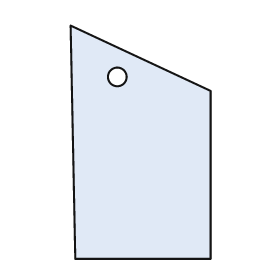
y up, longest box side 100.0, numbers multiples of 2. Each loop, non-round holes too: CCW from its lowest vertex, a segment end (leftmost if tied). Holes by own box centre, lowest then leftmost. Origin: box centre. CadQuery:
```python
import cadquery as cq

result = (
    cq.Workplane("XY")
    .moveTo(-28.0, -50.0)
    .lineTo(30.0, -50.0)
    .lineTo(30.0, 22.0)
    .lineTo(-30.0, 50.0)
    .close()
    .moveTo(-10.0, 28.0)
    .circle(4.0)
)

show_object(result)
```